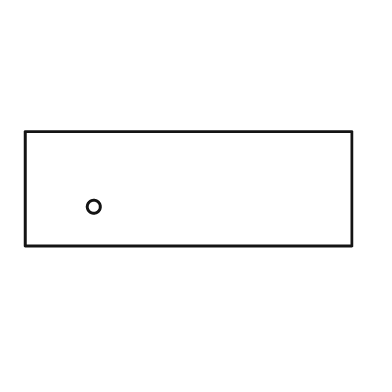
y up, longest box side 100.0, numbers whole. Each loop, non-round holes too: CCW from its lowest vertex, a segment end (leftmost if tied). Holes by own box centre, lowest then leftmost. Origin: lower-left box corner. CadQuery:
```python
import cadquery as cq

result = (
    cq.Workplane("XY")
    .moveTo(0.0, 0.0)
    .lineTo(100.0, 0.0)
    .lineTo(100.0, 35.0)
    .lineTo(0.0, 35.0)
    .close()
    .moveTo(21.0, 12.0)
    .circle(2.0)
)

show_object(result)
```